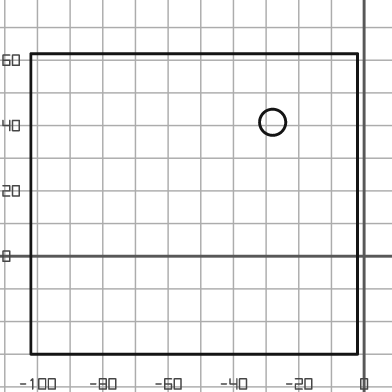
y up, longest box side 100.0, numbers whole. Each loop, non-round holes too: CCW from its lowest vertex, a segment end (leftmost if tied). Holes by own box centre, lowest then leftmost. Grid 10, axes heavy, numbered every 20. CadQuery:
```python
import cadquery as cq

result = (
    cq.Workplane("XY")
    .moveTo(-102.0, -30.0)
    .lineTo(-2.0, -30.0)
    .lineTo(-2.0, 62.0)
    .lineTo(-102.0, 62.0)
    .close()
    .moveTo(-28.0, 41.0)
    .circle(4.0)
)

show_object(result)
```